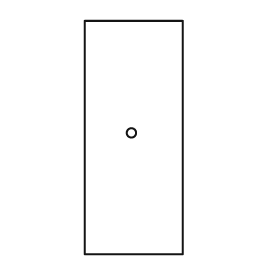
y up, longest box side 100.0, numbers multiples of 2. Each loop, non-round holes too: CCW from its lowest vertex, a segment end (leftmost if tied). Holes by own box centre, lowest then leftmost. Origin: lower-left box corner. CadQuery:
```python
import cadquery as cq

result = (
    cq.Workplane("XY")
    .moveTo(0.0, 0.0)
    .lineTo(42.0, 0.0)
    .lineTo(42.0, 100.0)
    .lineTo(0.0, 100.0)
    .close()
    .moveTo(20.0, 52.0)
    .circle(2.0)
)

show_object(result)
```